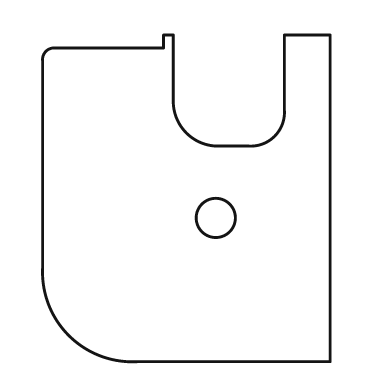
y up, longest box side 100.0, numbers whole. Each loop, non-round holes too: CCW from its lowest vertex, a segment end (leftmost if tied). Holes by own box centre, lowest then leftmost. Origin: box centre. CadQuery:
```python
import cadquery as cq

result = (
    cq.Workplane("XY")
    .moveTo(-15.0, -50.0)
    .lineTo(44.0, -50.0)
    .lineTo(44.0, 50.0)
    .lineTo(30.0, 50.0)
    .lineTo(30.0, 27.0)
    .threePointArc((27.0, 19.0), (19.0, 16.0))
    .lineTo(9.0, 16.0)
    .threePointArc((0.0, 20.0), (-4.0, 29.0))
    .lineTo(-4.0, 50.0)
    .lineTo(-7.0, 50.0)
    .lineTo(-7.0, 46.0)
    .lineTo(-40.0, 46.0)
    .threePointArc((-43.0, 45.0), (-44.0, 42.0))
    .lineTo(-44.0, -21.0)
    .threePointArc((-36.0, -42.0), (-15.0, -50.0))
    .close()
    .moveTo(9.0, -6.0)
    .circle(6.0)
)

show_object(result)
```